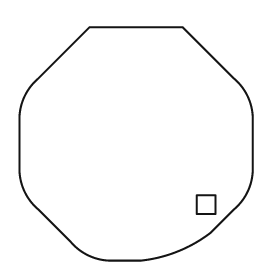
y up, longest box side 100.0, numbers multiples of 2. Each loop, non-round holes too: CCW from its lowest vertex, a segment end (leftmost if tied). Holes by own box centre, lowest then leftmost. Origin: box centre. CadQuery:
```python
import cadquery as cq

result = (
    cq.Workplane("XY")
    .moveTo(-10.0, -50.0)
    .lineTo(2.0, -50.0)
    .threePointArc((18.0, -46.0), (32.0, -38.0))
    .lineTo(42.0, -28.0)
    .threePointArc((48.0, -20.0), (50.0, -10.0))
    .lineTo(50.0, 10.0)
    .threePointArc((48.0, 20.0), (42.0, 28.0))
    .lineTo(20.0, 50.0)
    .lineTo(-20.0, 50.0)
    .lineTo(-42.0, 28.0)
    .threePointArc((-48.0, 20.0), (-50.0, 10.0))
    .lineTo(-50.0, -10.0)
    .threePointArc((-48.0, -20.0), (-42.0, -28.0))
    .lineTo(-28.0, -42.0)
    .threePointArc((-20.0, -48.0), (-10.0, -50.0))
    .close()
    .moveTo(26.0, -30.0)
    .lineTo(34.0, -30.0)
    .lineTo(34.0, -22.0)
    .lineTo(26.0, -22.0)
    .close()
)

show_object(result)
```